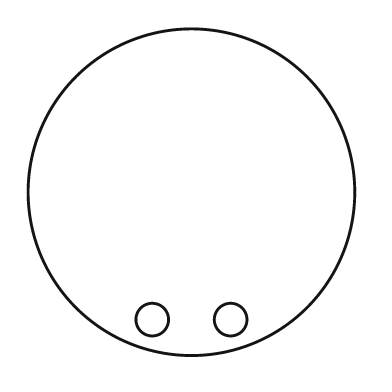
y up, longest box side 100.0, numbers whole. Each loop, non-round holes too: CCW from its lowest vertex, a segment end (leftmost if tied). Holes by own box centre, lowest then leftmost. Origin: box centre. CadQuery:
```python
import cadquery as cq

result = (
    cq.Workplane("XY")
    .moveTo(0.0, 0.0)
    .circle(50.0)
    .moveTo(-12.0, -39.0)
    .circle(5.0)
    .moveTo(12.0, -39.0)
    .circle(5.0)
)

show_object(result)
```